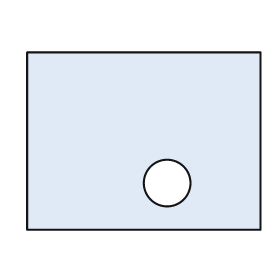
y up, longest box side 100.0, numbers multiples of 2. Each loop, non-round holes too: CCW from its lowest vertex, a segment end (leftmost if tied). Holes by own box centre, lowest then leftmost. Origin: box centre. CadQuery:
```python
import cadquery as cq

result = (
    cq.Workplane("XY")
    .moveTo(-50.0, -38.0)
    .lineTo(50.0, -38.0)
    .lineTo(50.0, 38.0)
    .lineTo(-50.0, 38.0)
    .close()
    .moveTo(10.0, -18.0)
    .circle(10.0)
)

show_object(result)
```